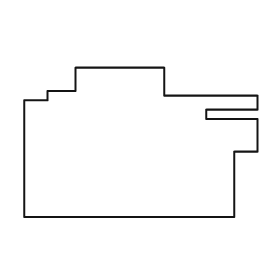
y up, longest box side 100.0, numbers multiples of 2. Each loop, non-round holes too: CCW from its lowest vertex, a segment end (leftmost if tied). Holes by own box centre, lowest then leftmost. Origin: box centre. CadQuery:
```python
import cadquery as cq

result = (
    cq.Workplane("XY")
    .moveTo(-50.0, -32.0)
    .lineTo(40.0, -32.0)
    .lineTo(40.0, -4.0)
    .lineTo(50.0, -4.0)
    .lineTo(50.0, 10.0)
    .lineTo(28.0, 10.0)
    .lineTo(28.0, 14.0)
    .lineTo(50.0, 14.0)
    .lineTo(50.0, 20.0)
    .lineTo(10.0, 20.0)
    .lineTo(10.0, 32.0)
    .lineTo(-28.0, 32.0)
    .lineTo(-28.0, 22.0)
    .lineTo(-40.0, 22.0)
    .lineTo(-40.0, 18.0)
    .lineTo(-50.0, 18.0)
    .close()
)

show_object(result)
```